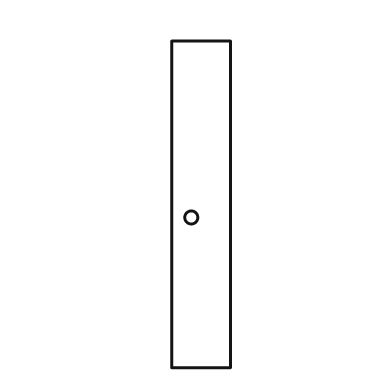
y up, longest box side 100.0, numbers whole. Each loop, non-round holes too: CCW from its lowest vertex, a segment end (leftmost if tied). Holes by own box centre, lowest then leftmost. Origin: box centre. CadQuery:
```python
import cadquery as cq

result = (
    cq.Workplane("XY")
    .moveTo(-9.0, -50.0)
    .lineTo(9.0, -50.0)
    .lineTo(9.0, 50.0)
    .lineTo(-9.0, 50.0)
    .close()
    .moveTo(-3.0, -4.0)
    .circle(2.0)
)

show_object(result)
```